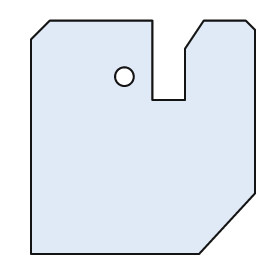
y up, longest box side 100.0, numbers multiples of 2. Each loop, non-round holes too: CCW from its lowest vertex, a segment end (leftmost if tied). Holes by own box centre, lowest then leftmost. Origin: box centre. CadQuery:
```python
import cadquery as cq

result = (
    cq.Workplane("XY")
    .moveTo(-48.0, -50.0)
    .lineTo(24.0, -50.0)
    .lineTo(48.0, -24.0)
    .lineTo(48.0, 46.0)
    .lineTo(44.0, 50.0)
    .lineTo(26.0, 50.0)
    .lineTo(18.0, 38.0)
    .lineTo(18.0, 16.0)
    .lineTo(4.0, 16.0)
    .lineTo(4.0, 50.0)
    .lineTo(-40.0, 50.0)
    .lineTo(-48.0, 42.0)
    .close()
    .moveTo(-8.0, 26.0)
    .circle(4.0)
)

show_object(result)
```